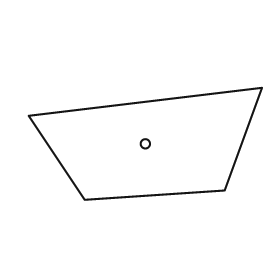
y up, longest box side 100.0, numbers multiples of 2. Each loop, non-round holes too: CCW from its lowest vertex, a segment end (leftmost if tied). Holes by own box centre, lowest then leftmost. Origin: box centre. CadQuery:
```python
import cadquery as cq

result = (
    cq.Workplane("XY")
    .moveTo(-26.0, -24.0)
    .lineTo(34.0, -20.0)
    .lineTo(50.0, 24.0)
    .lineTo(-50.0, 12.0)
    .close()
    .moveTo(0.0, 0.0)
    .circle(2.0)
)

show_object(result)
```